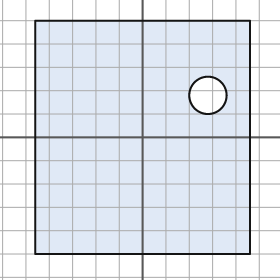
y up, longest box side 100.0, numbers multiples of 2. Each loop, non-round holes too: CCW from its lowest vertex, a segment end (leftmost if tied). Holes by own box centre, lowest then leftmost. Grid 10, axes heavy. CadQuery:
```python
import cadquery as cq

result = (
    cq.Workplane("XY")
    .moveTo(-46.0, -50.0)
    .lineTo(46.0, -50.0)
    .lineTo(46.0, 50.0)
    .lineTo(-46.0, 50.0)
    .close()
    .moveTo(28.0, 18.0)
    .circle(8.0)
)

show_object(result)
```